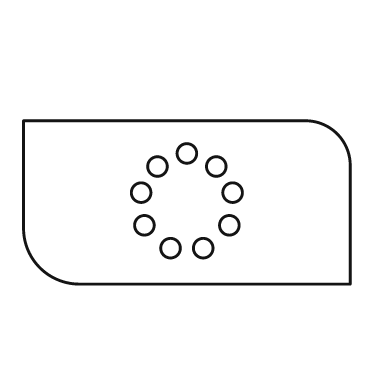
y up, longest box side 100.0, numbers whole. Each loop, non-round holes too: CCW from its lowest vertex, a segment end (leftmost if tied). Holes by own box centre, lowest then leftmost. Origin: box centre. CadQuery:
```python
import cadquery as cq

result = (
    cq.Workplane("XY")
    .moveTo(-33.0, -25.0)
    .lineTo(50.0, -25.0)
    .lineTo(50.0, 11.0)
    .threePointArc((46.0, 21.0), (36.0, 25.0))
    .lineTo(-50.0, 25.0)
    .lineTo(-50.0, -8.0)
    .threePointArc((-45.0, -20.0), (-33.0, -25.0))
    .close()
    .moveTo(-5.0, -14.0)
    .circle(3.0)
    .moveTo(5.0, -14.0)
    .circle(3.0)
    .moveTo(-13.0, -7.0)
    .circle(3.0)
    .moveTo(13.0, -7.0)
    .circle(3.0)
    .moveTo(-14.0, 3.0)
    .circle(3.0)
    .moveTo(14.0, 3.0)
    .circle(3.0)
    .moveTo(-9.0, 11.0)
    .circle(3.0)
    .moveTo(9.0, 11.0)
    .circle(3.0)
    .moveTo(0.0, 15.0)
    .circle(3.0)
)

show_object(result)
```